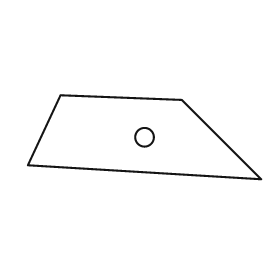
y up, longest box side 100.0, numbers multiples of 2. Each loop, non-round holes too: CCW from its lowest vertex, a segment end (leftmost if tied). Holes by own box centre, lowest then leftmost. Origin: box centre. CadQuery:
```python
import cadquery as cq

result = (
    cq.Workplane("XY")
    .moveTo(50.0, -18.0)
    .lineTo(16.0, 16.0)
    .lineTo(-36.0, 18.0)
    .lineTo(-50.0, -12.0)
    .close()
    .moveTo(0.0, 0.0)
    .circle(4.0)
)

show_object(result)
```